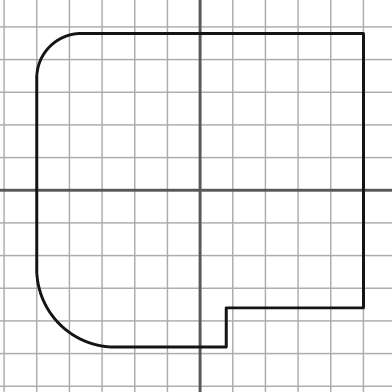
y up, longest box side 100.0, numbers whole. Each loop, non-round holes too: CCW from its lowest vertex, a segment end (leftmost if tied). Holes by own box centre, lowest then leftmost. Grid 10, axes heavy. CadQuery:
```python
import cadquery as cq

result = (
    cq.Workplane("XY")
    .moveTo(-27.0, -48.0)
    .lineTo(8.0, -48.0)
    .lineTo(8.0, -36.0)
    .lineTo(50.0, -36.0)
    .lineTo(50.0, 48.0)
    .lineTo(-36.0, 48.0)
    .threePointArc((-46.0, 44.0), (-50.0, 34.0))
    .lineTo(-50.0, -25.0)
    .threePointArc((-43.0, -41.0), (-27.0, -48.0))
    .close()
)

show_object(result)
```